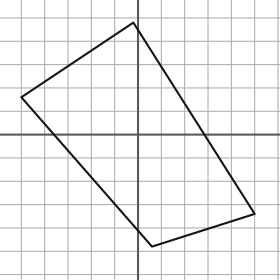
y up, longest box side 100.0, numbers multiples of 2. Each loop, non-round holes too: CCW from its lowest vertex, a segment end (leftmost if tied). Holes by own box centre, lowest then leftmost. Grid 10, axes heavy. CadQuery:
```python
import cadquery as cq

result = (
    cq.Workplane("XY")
    .moveTo(6.0, -48.0)
    .lineTo(50.0, -34.0)
    .lineTo(-2.0, 48.0)
    .lineTo(-50.0, 16.0)
    .close()
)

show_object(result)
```